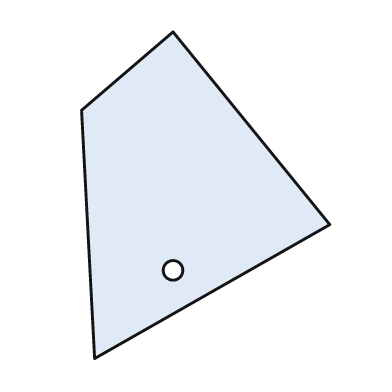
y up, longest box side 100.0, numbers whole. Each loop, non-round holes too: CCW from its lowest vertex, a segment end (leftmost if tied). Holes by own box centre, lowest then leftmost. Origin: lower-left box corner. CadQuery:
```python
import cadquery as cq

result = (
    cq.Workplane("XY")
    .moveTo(4.0, 0.0)
    .lineTo(76.0, 41.0)
    .lineTo(28.0, 100.0)
    .lineTo(0.0, 76.0)
    .close()
    .moveTo(28.0, 27.0)
    .circle(3.0)
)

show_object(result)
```